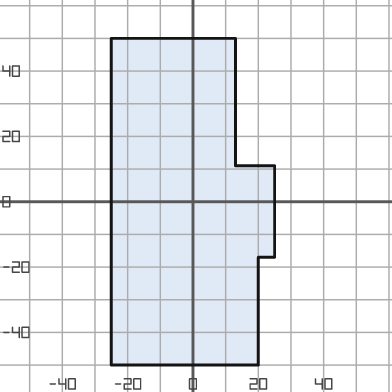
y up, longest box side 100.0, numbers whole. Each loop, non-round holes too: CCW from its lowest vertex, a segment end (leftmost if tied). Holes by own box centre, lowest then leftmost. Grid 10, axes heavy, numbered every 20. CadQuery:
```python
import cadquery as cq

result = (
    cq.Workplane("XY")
    .moveTo(-25.0, -50.0)
    .lineTo(20.0, -50.0)
    .lineTo(20.0, -17.0)
    .lineTo(25.0, -17.0)
    .lineTo(25.0, 11.0)
    .lineTo(13.0, 11.0)
    .lineTo(13.0, 50.0)
    .lineTo(-25.0, 50.0)
    .close()
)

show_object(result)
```